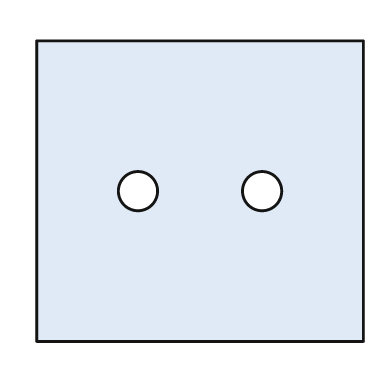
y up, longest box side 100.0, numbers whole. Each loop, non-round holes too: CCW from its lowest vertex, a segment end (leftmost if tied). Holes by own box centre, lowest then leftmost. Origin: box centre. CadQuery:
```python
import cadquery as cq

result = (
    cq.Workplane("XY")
    .moveTo(-50.0, -46.0)
    .lineTo(50.0, -46.0)
    .lineTo(50.0, 46.0)
    .lineTo(-50.0, 46.0)
    .close()
    .moveTo(-19.0, 0.0)
    .circle(6.0)
    .moveTo(19.0, 0.0)
    .circle(6.0)
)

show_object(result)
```